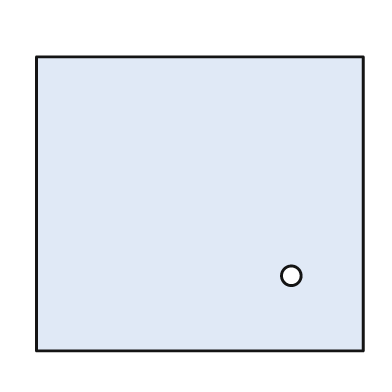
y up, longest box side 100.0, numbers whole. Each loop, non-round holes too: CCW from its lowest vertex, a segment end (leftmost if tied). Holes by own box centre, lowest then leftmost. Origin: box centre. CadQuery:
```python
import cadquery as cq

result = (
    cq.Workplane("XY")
    .moveTo(-50.0, -45.0)
    .lineTo(50.0, -45.0)
    .lineTo(50.0, 45.0)
    .lineTo(-50.0, 45.0)
    .close()
    .moveTo(28.0, -22.0)
    .circle(3.0)
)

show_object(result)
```